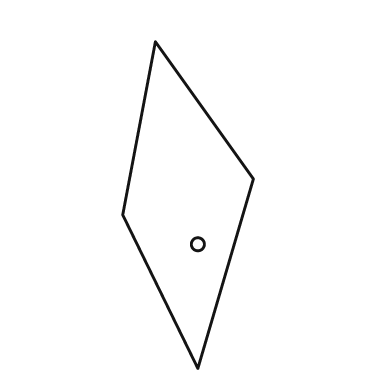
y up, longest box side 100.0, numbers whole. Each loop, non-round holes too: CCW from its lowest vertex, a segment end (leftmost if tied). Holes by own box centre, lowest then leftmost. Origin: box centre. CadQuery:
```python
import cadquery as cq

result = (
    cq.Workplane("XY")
    .moveTo(3.0, -50.0)
    .lineTo(20.0, 8.0)
    .lineTo(-10.0, 50.0)
    .lineTo(-20.0, -3.0)
    .close()
    .moveTo(3.0, -12.0)
    .circle(2.0)
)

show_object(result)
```